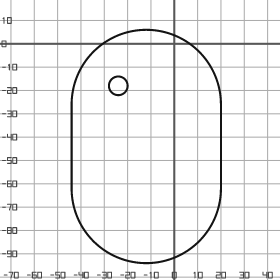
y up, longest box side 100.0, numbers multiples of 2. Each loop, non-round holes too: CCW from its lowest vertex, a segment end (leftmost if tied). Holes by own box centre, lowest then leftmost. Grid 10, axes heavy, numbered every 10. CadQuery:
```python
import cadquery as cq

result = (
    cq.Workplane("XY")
    .moveTo(-44.0, -62.0)
    .threePointArc((-12.0, -94.0), (20.0, -62.0))
    .lineTo(20.0, -26.0)
    .threePointArc((-12.0, 6.0), (-44.0, -26.0))
    .close()
    .moveTo(-24.0, -18.0)
    .circle(4.0)
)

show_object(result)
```